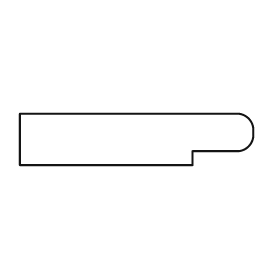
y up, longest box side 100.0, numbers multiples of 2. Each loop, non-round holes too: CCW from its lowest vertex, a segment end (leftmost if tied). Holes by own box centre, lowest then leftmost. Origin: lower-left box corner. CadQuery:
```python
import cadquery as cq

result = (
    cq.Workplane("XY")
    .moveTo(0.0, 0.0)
    .lineTo(74.0, 0.0)
    .lineTo(74.0, 6.0)
    .lineTo(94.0, 6.0)
    .threePointArc((98.0, 8.0), (100.0, 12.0))
    .lineTo(100.0, 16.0)
    .threePointArc((98.0, 20.0), (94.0, 22.0))
    .lineTo(0.0, 22.0)
    .close()
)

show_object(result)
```